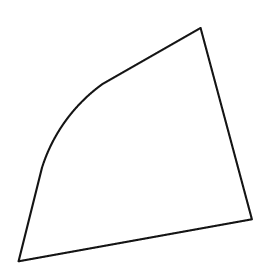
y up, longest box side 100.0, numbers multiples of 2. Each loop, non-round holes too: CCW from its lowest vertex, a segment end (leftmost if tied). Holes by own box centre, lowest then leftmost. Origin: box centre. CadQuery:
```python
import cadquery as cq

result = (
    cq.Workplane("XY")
    .moveTo(-50.0, -50.0)
    .lineTo(50.0, -32.0)
    .lineTo(28.0, 50.0)
    .lineTo(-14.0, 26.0)
    .threePointArc((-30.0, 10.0), (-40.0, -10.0))
    .close()
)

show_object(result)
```